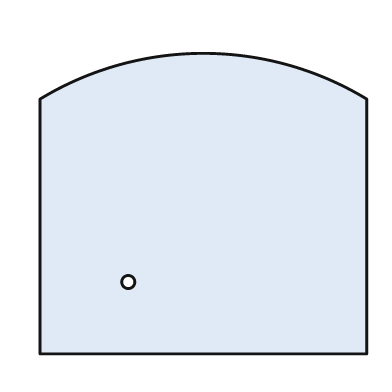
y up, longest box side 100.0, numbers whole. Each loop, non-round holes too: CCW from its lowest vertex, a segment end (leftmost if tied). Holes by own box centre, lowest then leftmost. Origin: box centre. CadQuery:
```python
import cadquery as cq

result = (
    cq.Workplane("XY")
    .moveTo(-50.0, -46.0)
    .lineTo(50.0, -46.0)
    .lineTo(50.0, 32.0)
    .threePointArc((0.0, 46.0), (-50.0, 32.0))
    .close()
    .moveTo(-23.0, -24.0)
    .circle(2.0)
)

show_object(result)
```